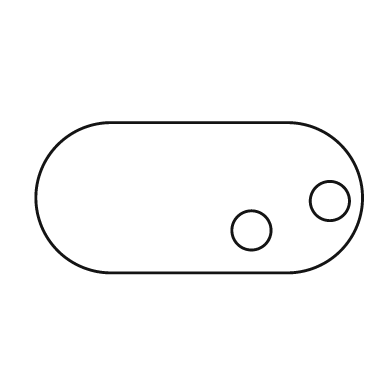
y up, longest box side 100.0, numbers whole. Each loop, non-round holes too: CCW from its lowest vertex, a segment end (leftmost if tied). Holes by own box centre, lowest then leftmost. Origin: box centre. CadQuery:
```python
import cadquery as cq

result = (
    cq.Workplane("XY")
    .moveTo(-27.0, -23.0)
    .lineTo(27.0, -23.0)
    .threePointArc((50.0, 0.0), (27.0, 23.0))
    .lineTo(-27.0, 23.0)
    .threePointArc((-50.0, 0.0), (-27.0, -23.0))
    .close()
    .moveTo(16.0, -10.0)
    .circle(6.0)
    .moveTo(40.0, -1.0)
    .circle(6.0)
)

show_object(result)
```